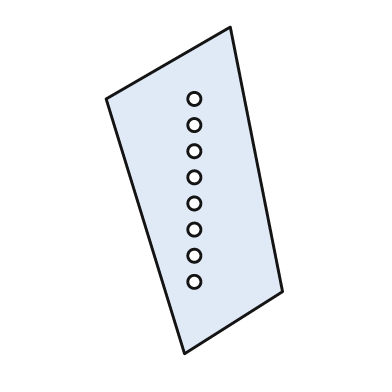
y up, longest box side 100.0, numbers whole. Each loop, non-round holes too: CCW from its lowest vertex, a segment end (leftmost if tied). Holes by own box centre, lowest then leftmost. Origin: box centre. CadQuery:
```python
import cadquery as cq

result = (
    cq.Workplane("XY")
    .moveTo(-3.0, -50.0)
    .lineTo(27.0, -31.0)
    .lineTo(11.0, 50.0)
    .lineTo(-27.0, 28.0)
    .close()
    .moveTo(0.0, -28.0)
    .circle(2.0)
    .moveTo(0.0, -20.0)
    .circle(2.0)
    .moveTo(0.0, -12.0)
    .circle(2.0)
    .moveTo(0.0, -4.0)
    .circle(2.0)
    .moveTo(0.0, 4.0)
    .circle(2.0)
    .moveTo(0.0, 12.0)
    .circle(2.0)
    .moveTo(0.0, 20.0)
    .circle(2.0)
    .moveTo(0.0, 28.0)
    .circle(2.0)
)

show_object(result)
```